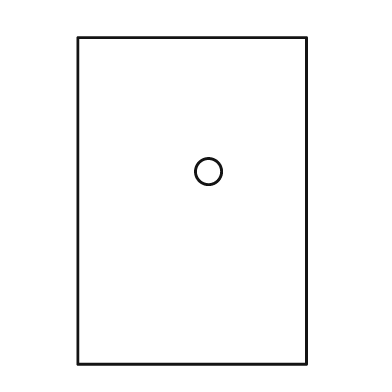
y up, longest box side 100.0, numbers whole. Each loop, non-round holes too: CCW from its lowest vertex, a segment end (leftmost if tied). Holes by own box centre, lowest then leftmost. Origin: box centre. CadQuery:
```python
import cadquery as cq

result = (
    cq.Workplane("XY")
    .moveTo(-35.0, -50.0)
    .lineTo(35.0, -50.0)
    .lineTo(35.0, 50.0)
    .lineTo(-35.0, 50.0)
    .close()
    .moveTo(5.0, 9.0)
    .circle(4.0)
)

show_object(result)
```